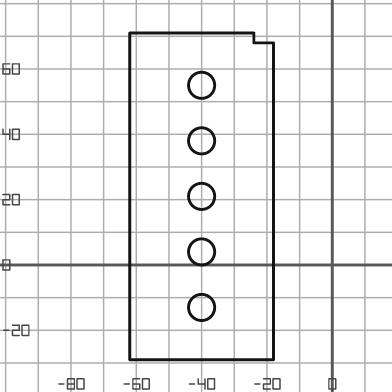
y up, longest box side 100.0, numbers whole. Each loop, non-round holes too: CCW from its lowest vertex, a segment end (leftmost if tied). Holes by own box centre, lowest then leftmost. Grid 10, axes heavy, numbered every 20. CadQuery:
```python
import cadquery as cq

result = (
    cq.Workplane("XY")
    .moveTo(-62.0, -29.0)
    .lineTo(-18.0, -29.0)
    .lineTo(-18.0, 68.0)
    .lineTo(-24.0, 68.0)
    .lineTo(-24.0, 71.0)
    .lineTo(-62.0, 71.0)
    .close()
    .moveTo(-40.0, -13.0)
    .circle(4.0)
    .moveTo(-40.0, 4.0)
    .circle(4.0)
    .moveTo(-40.0, 21.0)
    .circle(4.0)
    .moveTo(-40.0, 38.0)
    .circle(4.0)
    .moveTo(-40.0, 55.0)
    .circle(4.0)
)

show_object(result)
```